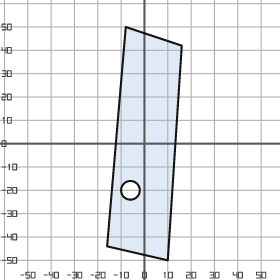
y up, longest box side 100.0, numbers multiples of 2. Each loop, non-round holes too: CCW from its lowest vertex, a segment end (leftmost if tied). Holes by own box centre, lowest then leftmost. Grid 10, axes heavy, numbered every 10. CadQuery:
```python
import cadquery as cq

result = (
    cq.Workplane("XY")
    .moveTo(10.0, -50.0)
    .lineTo(16.0, 42.0)
    .lineTo(-8.0, 50.0)
    .lineTo(-16.0, -44.0)
    .close()
    .moveTo(-6.0, -20.0)
    .circle(4.0)
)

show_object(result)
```